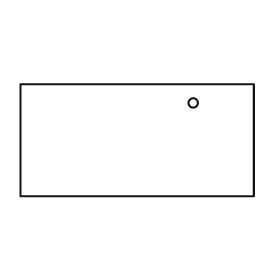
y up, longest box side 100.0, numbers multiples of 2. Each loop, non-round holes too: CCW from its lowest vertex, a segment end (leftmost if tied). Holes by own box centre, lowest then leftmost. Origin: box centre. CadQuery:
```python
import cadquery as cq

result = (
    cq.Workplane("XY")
    .moveTo(-50.0, -24.0)
    .lineTo(50.0, -24.0)
    .lineTo(50.0, 24.0)
    .lineTo(-50.0, 24.0)
    .close()
    .moveTo(24.0, 16.0)
    .circle(2.0)
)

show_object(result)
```